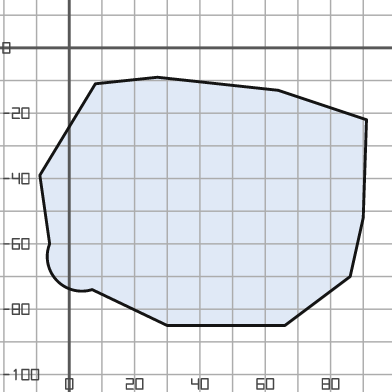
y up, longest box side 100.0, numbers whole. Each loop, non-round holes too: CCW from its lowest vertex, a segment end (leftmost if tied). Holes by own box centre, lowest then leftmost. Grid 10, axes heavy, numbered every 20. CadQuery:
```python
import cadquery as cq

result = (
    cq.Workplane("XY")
    .moveTo(30.0, -85.0)
    .lineTo(66.0, -85.0)
    .lineTo(86.0, -70.0)
    .lineTo(90.0, -52.0)
    .lineTo(91.0, -22.0)
    .lineTo(64.0, -13.0)
    .lineTo(27.0, -9.0)
    .lineTo(8.0, -11.0)
    .lineTo(-9.0, -39.0)
    .lineTo(-6.0, -60.0)
    .threePointArc((-4.0, -71.0), (7.0, -74.0))
    .close()
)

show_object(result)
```